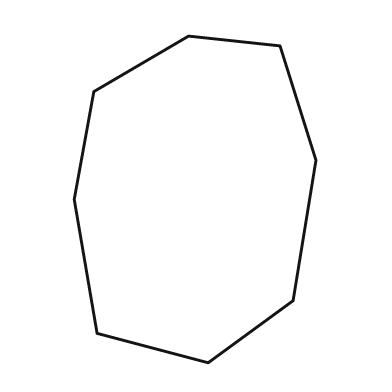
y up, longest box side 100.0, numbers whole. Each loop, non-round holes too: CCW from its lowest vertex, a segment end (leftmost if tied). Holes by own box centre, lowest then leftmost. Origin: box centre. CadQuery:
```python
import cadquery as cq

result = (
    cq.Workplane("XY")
    .moveTo(4.0, -50.0)
    .lineTo(30.0, -31.0)
    .lineTo(37.0, 12.0)
    .lineTo(26.0, 47.0)
    .lineTo(-2.0, 50.0)
    .lineTo(-31.0, 33.0)
    .lineTo(-37.0, 0.0)
    .lineTo(-30.0, -41.0)
    .close()
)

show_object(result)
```